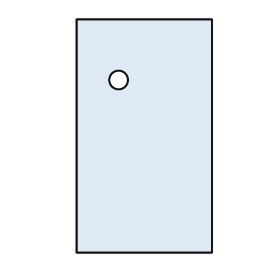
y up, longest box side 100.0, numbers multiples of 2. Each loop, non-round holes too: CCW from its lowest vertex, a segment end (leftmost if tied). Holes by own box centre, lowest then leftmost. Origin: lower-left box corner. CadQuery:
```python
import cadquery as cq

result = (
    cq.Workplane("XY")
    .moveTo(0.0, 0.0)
    .lineTo(58.0, 0.0)
    .lineTo(58.0, 100.0)
    .lineTo(0.0, 100.0)
    .close()
    .moveTo(18.0, 74.0)
    .circle(4.0)
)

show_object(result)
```